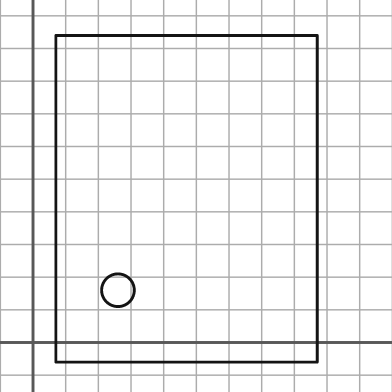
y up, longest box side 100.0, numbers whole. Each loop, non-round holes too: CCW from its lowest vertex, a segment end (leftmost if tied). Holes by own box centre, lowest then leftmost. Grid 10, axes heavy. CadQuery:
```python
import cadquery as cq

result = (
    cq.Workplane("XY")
    .moveTo(7.0, -6.0)
    .lineTo(87.0, -6.0)
    .lineTo(87.0, 94.0)
    .lineTo(7.0, 94.0)
    .close()
    .moveTo(26.0, 16.0)
    .circle(5.0)
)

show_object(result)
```